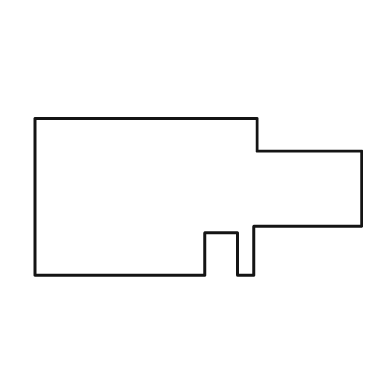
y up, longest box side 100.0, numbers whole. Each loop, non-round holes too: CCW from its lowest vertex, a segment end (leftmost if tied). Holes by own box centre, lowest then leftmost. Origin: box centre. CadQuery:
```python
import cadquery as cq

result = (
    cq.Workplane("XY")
    .moveTo(-50.0, -24.0)
    .lineTo(2.0, -24.0)
    .lineTo(2.0, -11.0)
    .lineTo(12.0, -11.0)
    .lineTo(12.0, -24.0)
    .lineTo(17.0, -24.0)
    .lineTo(17.0, -9.0)
    .lineTo(50.0, -9.0)
    .lineTo(50.0, 14.0)
    .lineTo(18.0, 14.0)
    .lineTo(18.0, 24.0)
    .lineTo(-50.0, 24.0)
    .close()
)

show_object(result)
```